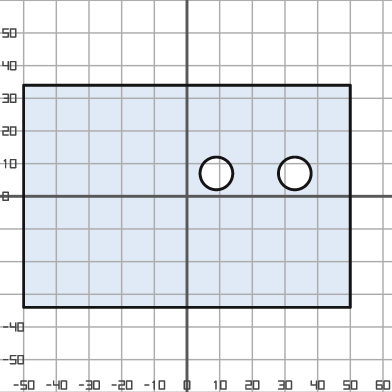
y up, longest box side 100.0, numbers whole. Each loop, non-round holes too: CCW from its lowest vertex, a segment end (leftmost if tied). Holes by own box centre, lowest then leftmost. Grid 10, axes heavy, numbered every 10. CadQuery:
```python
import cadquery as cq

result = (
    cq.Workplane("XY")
    .moveTo(-50.0, -34.0)
    .lineTo(50.0, -34.0)
    .lineTo(50.0, 34.0)
    .lineTo(-50.0, 34.0)
    .close()
    .moveTo(9.0, 7.0)
    .circle(5.0)
    .moveTo(33.0, 7.0)
    .circle(5.0)
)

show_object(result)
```